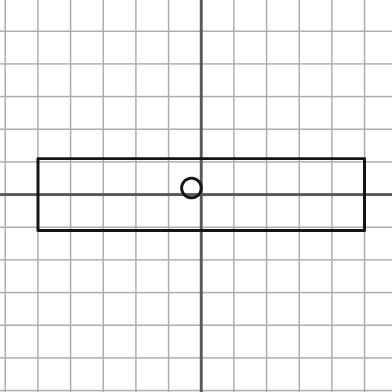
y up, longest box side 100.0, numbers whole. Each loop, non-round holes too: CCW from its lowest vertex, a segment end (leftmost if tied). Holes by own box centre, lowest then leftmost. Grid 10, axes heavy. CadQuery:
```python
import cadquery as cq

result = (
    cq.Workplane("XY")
    .moveTo(-50.0, -11.0)
    .lineTo(50.0, -11.0)
    .lineTo(50.0, 11.0)
    .lineTo(-50.0, 11.0)
    .close()
    .moveTo(-3.0, 2.0)
    .circle(3.0)
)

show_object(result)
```